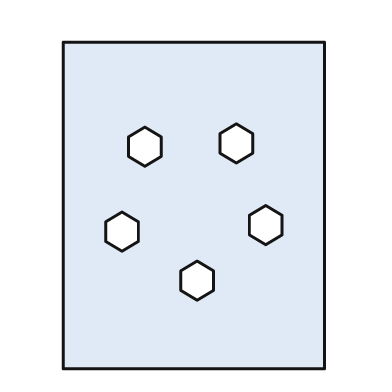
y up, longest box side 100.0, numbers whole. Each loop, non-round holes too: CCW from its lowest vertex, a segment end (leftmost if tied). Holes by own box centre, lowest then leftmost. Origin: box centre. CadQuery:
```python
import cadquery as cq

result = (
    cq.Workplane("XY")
    .moveTo(-40.0, -50.0)
    .lineTo(40.0, -50.0)
    .lineTo(40.0, 50.0)
    .lineTo(-40.0, 50.0)
    .close()
    .moveTo(1.0, -29.0)
    .lineTo(6.0, -26.0)
    .lineTo(6.0, -20.0)
    .lineTo(1.0, -17.0)
    .lineTo(-4.0, -20.0)
    .lineTo(-4.0, -26.0)
    .close()
    .moveTo(-22.0, -14.0)
    .lineTo(-17.0, -11.0)
    .lineTo(-17.0, -5.0)
    .lineTo(-22.0, -2.0)
    .lineTo(-27.0, -5.0)
    .lineTo(-27.0, -11.0)
    .close()
    .moveTo(22.0, -12.0)
    .lineTo(27.0, -9.0)
    .lineTo(27.0, -3.0)
    .lineTo(22.0, 0.0)
    .lineTo(17.0, -3.0)
    .lineTo(17.0, -9.0)
    .close()
    .moveTo(-15.0, 12.0)
    .lineTo(-10.0, 15.0)
    .lineTo(-10.0, 21.0)
    .lineTo(-15.0, 24.0)
    .lineTo(-20.0, 21.0)
    .lineTo(-20.0, 15.0)
    .close()
    .moveTo(13.0, 13.0)
    .lineTo(18.0, 16.0)
    .lineTo(18.0, 22.0)
    .lineTo(13.0, 25.0)
    .lineTo(8.0, 22.0)
    .lineTo(8.0, 16.0)
    .close()
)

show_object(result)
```